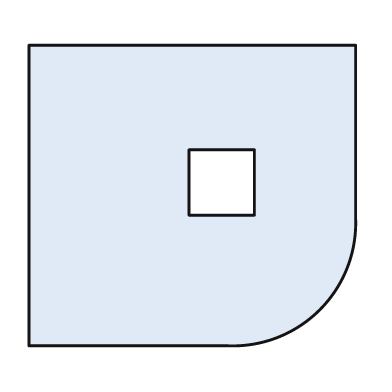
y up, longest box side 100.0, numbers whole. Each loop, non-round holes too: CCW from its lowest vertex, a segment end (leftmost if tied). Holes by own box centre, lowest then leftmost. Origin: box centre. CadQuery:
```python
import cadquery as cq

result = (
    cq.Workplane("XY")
    .moveTo(-50.0, -46.0)
    .lineTo(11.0, -46.0)
    .threePointArc((39.0, -35.0), (50.0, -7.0))
    .lineTo(50.0, 46.0)
    .lineTo(-50.0, 46.0)
    .close()
    .moveTo(-1.0, -6.0)
    .lineTo(19.0, -6.0)
    .lineTo(19.0, 14.0)
    .lineTo(-1.0, 14.0)
    .close()
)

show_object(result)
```